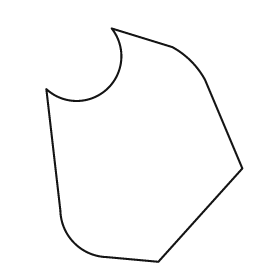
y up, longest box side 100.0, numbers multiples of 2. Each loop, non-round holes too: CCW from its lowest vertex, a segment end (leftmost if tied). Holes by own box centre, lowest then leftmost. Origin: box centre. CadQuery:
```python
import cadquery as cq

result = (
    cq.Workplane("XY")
    .moveTo(6.0, -50.0)
    .lineTo(42.0, -10.0)
    .lineTo(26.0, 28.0)
    .threePointArc((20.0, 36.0), (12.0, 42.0))
    .lineTo(-14.0, 50.0)
    .threePointArc((-16.0, 24.0), (-42.0, 24.0))
    .lineTo(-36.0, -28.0)
    .threePointArc((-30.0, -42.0), (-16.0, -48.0))
    .close()
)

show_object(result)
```